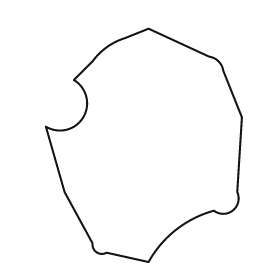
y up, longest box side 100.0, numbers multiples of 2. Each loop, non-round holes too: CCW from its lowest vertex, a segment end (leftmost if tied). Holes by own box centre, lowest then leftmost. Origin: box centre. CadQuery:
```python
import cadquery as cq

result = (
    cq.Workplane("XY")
    .moveTo(2.0, -50.0)
    .threePointArc((14.0, -36.0), (30.0, -28.0))
    .threePointArc((38.0, -28.0), (40.0, -20.0))
    .lineTo(42.0, 12.0)
    .lineTo(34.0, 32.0)
    .threePointArc((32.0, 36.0), (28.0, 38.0))
    .lineTo(2.0, 50.0)
    .lineTo(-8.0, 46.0)
    .threePointArc((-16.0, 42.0), (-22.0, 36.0))
    .lineTo(-30.0, 28.0)
    .threePointArc((-26.0, 12.0), (-42.0, 8.0))
    .lineTo(-34.0, -20.0)
    .lineTo(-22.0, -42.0)
    .threePointArc((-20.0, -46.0), (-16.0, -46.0))
    .close()
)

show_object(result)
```